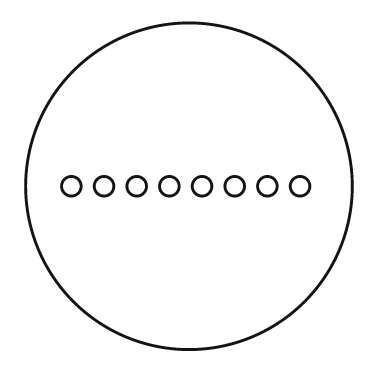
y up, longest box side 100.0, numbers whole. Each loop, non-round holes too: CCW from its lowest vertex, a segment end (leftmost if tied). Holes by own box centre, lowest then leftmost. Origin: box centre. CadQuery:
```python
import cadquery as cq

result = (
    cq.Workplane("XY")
    .moveTo(0.0, 0.0)
    .circle(50.0)
    .moveTo(-36.0, 0.0)
    .circle(3.0)
    .moveTo(-26.0, 0.0)
    .circle(3.0)
    .moveTo(-16.0, 0.0)
    .circle(3.0)
    .moveTo(-6.0, 0.0)
    .circle(3.0)
    .moveTo(4.0, 0.0)
    .circle(3.0)
    .moveTo(14.0, 0.0)
    .circle(3.0)
    .moveTo(24.0, 0.0)
    .circle(3.0)
    .moveTo(34.0, 0.0)
    .circle(3.0)
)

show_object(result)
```